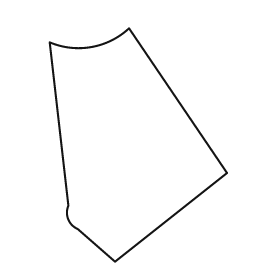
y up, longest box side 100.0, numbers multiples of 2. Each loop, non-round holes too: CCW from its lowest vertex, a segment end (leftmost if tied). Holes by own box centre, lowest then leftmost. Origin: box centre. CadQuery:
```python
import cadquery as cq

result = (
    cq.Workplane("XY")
    .moveTo(-10.0, -50.0)
    .lineTo(38.0, -12.0)
    .lineTo(-4.0, 50.0)
    .threePointArc((-20.0, 42.0), (-38.0, 44.0))
    .lineTo(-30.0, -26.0)
    .threePointArc((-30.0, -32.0), (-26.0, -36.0))
    .close()
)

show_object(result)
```